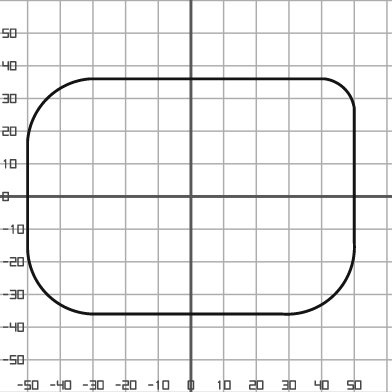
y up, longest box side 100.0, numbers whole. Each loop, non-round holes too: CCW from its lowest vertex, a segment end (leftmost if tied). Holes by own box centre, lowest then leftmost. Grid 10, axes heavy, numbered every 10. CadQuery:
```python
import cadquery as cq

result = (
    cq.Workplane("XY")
    .moveTo(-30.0, -36.0)
    .lineTo(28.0, -36.0)
    .threePointArc((44.0, -30.0), (50.0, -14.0))
    .lineTo(50.0, 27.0)
    .threePointArc((47.0, 33.0), (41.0, 36.0))
    .lineTo(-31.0, 36.0)
    .threePointArc((-44.0, 30.0), (-50.0, 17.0))
    .lineTo(-50.0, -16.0)
    .threePointArc((-44.0, -30.0), (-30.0, -36.0))
    .close()
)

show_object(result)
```